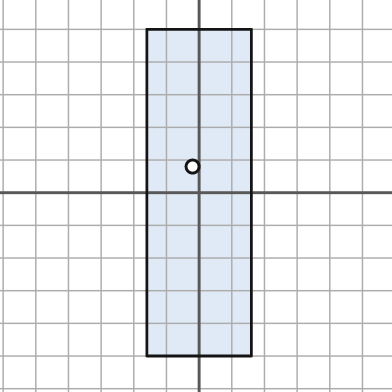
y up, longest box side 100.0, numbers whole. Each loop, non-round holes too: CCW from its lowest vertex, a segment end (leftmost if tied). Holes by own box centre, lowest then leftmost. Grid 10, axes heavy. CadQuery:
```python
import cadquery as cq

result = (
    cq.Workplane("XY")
    .moveTo(-16.0, -50.0)
    .lineTo(16.0, -50.0)
    .lineTo(16.0, 50.0)
    .lineTo(-16.0, 50.0)
    .close()
    .moveTo(-2.0, 8.0)
    .circle(2.0)
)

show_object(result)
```